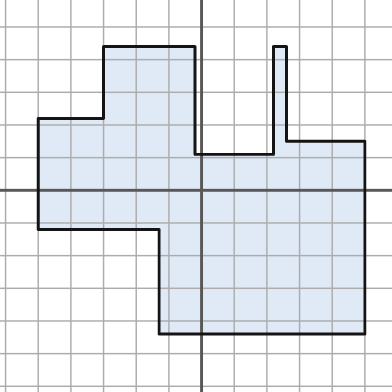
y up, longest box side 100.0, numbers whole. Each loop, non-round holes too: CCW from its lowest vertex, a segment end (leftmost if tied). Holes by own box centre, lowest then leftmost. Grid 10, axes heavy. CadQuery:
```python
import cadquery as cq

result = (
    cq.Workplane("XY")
    .moveTo(-13.0, -44.0)
    .lineTo(50.0, -44.0)
    .lineTo(50.0, 15.0)
    .lineTo(26.0, 15.0)
    .lineTo(26.0, 44.0)
    .lineTo(22.0, 44.0)
    .lineTo(22.0, 11.0)
    .lineTo(-2.0, 11.0)
    .lineTo(-2.0, 44.0)
    .lineTo(-30.0, 44.0)
    .lineTo(-30.0, 22.0)
    .lineTo(-50.0, 22.0)
    .lineTo(-50.0, -12.0)
    .lineTo(-13.0, -12.0)
    .close()
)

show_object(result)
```